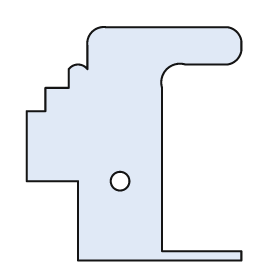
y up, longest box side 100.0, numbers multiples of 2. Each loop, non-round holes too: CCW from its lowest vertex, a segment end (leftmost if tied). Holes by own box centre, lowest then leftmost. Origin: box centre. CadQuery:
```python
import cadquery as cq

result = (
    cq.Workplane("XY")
    .moveTo(-24.0, -50.0)
    .lineTo(46.0, -50.0)
    .lineTo(46.0, -46.0)
    .lineTo(12.0, -46.0)
    .lineTo(12.0, 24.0)
    .threePointArc((14.0, 32.0), (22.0, 34.0))
    .lineTo(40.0, 34.0)
    .threePointArc((44.0, 36.0), (46.0, 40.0))
    .lineTo(46.0, 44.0)
    .threePointArc((44.0, 48.0), (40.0, 50.0))
    .lineTo(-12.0, 50.0)
    .threePointArc((-18.0, 48.0), (-20.0, 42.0))
    .lineTo(-20.0, 32.0)
    .threePointArc((-24.0, 34.0), (-28.0, 32.0))
    .lineTo(-28.0, 24.0)
    .lineTo(-38.0, 24.0)
    .lineTo(-38.0, 14.0)
    .lineTo(-46.0, 14.0)
    .lineTo(-46.0, -16.0)
    .lineTo(-24.0, -16.0)
    .close()
    .moveTo(-6.0, -16.0)
    .circle(4.0)
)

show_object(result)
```